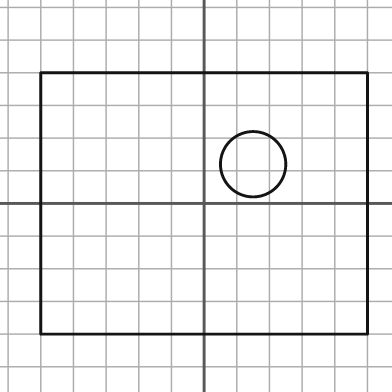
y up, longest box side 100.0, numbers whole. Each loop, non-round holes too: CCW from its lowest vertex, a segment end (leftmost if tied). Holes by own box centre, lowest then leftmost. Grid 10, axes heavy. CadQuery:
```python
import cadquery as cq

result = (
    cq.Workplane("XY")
    .moveTo(-50.0, -40.0)
    .lineTo(50.0, -40.0)
    .lineTo(50.0, 40.0)
    .lineTo(-50.0, 40.0)
    .close()
    .moveTo(15.0, 12.0)
    .circle(10.0)
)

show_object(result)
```